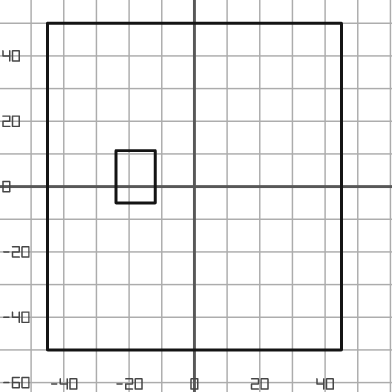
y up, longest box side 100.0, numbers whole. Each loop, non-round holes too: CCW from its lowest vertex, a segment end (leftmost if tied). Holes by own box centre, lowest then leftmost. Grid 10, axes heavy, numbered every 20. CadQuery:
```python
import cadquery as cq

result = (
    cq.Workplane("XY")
    .moveTo(-45.0, -50.0)
    .lineTo(45.0, -50.0)
    .lineTo(45.0, 50.0)
    .lineTo(-45.0, 50.0)
    .close()
    .moveTo(-24.0, -5.0)
    .lineTo(-12.0, -5.0)
    .lineTo(-12.0, 11.0)
    .lineTo(-24.0, 11.0)
    .close()
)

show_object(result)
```